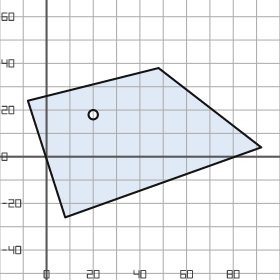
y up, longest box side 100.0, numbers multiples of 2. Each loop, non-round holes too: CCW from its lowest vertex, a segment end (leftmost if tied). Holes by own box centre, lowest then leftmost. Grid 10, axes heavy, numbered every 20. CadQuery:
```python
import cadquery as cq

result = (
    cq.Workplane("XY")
    .moveTo(8.0, -26.0)
    .lineTo(92.0, 4.0)
    .lineTo(48.0, 38.0)
    .lineTo(-8.0, 24.0)
    .close()
    .moveTo(20.0, 18.0)
    .circle(2.0)
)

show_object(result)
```